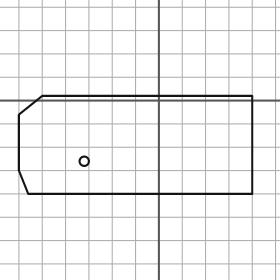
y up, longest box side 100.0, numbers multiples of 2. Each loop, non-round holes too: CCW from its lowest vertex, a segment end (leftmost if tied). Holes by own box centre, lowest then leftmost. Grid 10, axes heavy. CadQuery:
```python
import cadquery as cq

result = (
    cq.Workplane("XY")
    .moveTo(-56.0, -40.0)
    .lineTo(40.0, -40.0)
    .lineTo(40.0, 2.0)
    .lineTo(-50.0, 2.0)
    .lineTo(-60.0, -6.0)
    .lineTo(-60.0, -30.0)
    .close()
    .moveTo(-32.0, -26.0)
    .circle(2.0)
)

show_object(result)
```